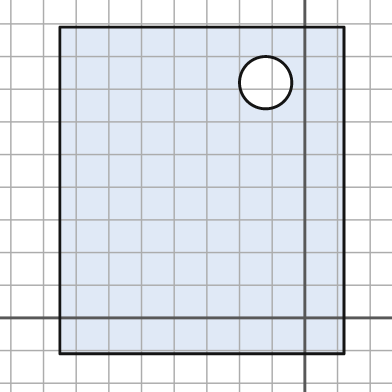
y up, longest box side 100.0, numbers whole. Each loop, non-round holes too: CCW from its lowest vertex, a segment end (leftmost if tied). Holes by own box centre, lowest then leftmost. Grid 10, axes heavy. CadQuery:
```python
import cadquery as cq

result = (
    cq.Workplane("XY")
    .moveTo(-75.0, -11.0)
    .lineTo(12.0, -11.0)
    .lineTo(12.0, 89.0)
    .lineTo(-75.0, 89.0)
    .close()
    .moveTo(-12.0, 72.0)
    .circle(8.0)
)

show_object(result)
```